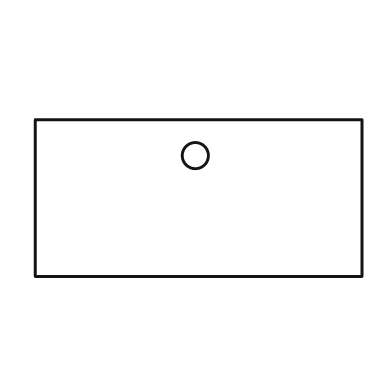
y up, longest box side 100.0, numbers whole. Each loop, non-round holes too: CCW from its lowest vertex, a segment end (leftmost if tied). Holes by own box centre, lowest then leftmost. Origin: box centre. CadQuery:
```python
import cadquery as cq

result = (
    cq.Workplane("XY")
    .moveTo(-50.0, -24.0)
    .lineTo(50.0, -24.0)
    .lineTo(50.0, 24.0)
    .lineTo(-50.0, 24.0)
    .close()
    .moveTo(-1.0, 13.0)
    .circle(4.0)
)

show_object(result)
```